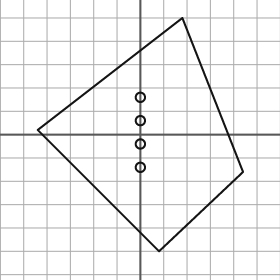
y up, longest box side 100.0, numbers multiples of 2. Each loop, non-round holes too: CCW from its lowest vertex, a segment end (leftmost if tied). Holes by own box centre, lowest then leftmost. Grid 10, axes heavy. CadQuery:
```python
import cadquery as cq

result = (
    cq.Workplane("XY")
    .moveTo(8.0, -50.0)
    .lineTo(44.0, -16.0)
    .lineTo(18.0, 50.0)
    .lineTo(-44.0, 2.0)
    .close()
    .moveTo(0.0, -14.0)
    .circle(2.0)
    .moveTo(0.0, -4.0)
    .circle(2.0)
    .moveTo(0.0, 6.0)
    .circle(2.0)
    .moveTo(0.0, 16.0)
    .circle(2.0)
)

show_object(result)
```